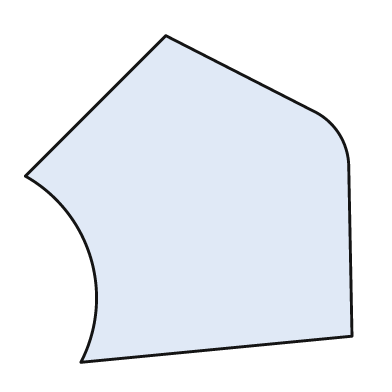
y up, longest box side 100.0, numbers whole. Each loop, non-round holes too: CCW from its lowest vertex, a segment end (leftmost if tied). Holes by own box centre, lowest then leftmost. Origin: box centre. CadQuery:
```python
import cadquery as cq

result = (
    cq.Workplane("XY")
    .moveTo(-33.0, -50.0)
    .lineTo(50.0, -42.0)
    .lineTo(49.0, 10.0)
    .threePointArc((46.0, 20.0), (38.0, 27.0))
    .lineTo(-7.0, 50.0)
    .lineTo(-50.0, 7.0)
    .threePointArc((-30.0, -18.0), (-33.0, -50.0))
    .close()
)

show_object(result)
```